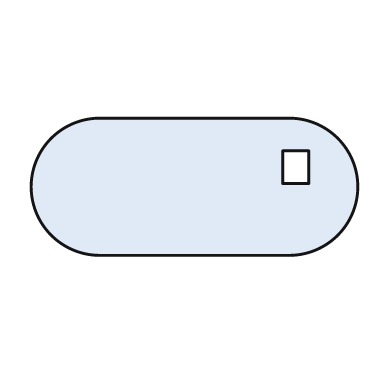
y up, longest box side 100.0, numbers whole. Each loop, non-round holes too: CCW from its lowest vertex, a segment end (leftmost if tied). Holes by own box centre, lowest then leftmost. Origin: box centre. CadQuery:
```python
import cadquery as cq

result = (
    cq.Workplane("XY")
    .moveTo(-29.0, -21.0)
    .lineTo(29.0, -21.0)
    .threePointArc((50.0, 0.0), (29.0, 21.0))
    .lineTo(-29.0, 21.0)
    .threePointArc((-50.0, 0.0), (-29.0, -21.0))
    .close()
    .moveTo(27.0, 1.0)
    .lineTo(35.0, 1.0)
    .lineTo(35.0, 11.0)
    .lineTo(27.0, 11.0)
    .close()
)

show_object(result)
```